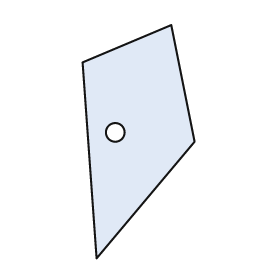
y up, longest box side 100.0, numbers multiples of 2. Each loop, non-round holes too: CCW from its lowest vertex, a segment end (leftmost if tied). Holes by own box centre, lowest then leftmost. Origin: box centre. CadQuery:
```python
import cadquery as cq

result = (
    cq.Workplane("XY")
    .moveTo(-18.0, -50.0)
    .lineTo(24.0, 0.0)
    .lineTo(14.0, 50.0)
    .lineTo(-24.0, 34.0)
    .close()
    .moveTo(-10.0, 4.0)
    .circle(4.0)
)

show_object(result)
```